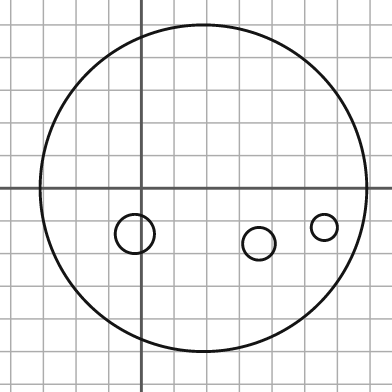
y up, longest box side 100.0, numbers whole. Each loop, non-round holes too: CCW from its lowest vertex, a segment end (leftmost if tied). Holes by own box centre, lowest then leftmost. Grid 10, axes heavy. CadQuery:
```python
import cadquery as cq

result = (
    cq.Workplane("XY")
    .moveTo(19.0, 0.0)
    .circle(50.0)
    .moveTo(36.0, -17.0)
    .circle(5.0)
    .moveTo(-2.0, -14.0)
    .circle(6.0)
    .moveTo(56.0, -12.0)
    .circle(4.0)
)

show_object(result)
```